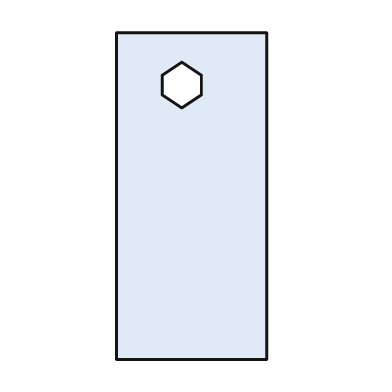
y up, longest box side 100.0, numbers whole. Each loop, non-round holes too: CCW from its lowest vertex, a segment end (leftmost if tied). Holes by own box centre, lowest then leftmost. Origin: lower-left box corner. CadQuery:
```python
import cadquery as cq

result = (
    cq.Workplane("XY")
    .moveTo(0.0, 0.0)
    .lineTo(46.0, 0.0)
    .lineTo(46.0, 100.0)
    .lineTo(0.0, 100.0)
    .close()
    .moveTo(20.0, 77.0)
    .lineTo(26.0, 81.0)
    .lineTo(26.0, 87.0)
    .lineTo(20.0, 91.0)
    .lineTo(14.0, 87.0)
    .lineTo(14.0, 81.0)
    .close()
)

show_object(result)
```